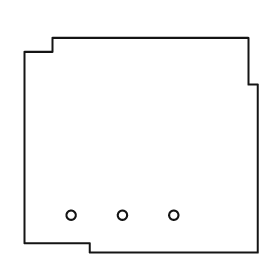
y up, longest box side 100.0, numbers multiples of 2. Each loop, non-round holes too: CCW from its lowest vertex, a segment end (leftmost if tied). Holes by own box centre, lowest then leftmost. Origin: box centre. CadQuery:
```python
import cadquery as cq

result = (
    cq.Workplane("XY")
    .moveTo(-22.0, -46.0)
    .lineTo(50.0, -46.0)
    .lineTo(50.0, 26.0)
    .lineTo(46.0, 26.0)
    .lineTo(46.0, 46.0)
    .lineTo(-38.0, 46.0)
    .lineTo(-38.0, 40.0)
    .lineTo(-50.0, 40.0)
    .lineTo(-50.0, -42.0)
    .lineTo(-22.0, -42.0)
    .close()
    .moveTo(-30.0, -30.0)
    .circle(2.0)
    .moveTo(-8.0, -30.0)
    .circle(2.0)
    .moveTo(14.0, -30.0)
    .circle(2.0)
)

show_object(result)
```